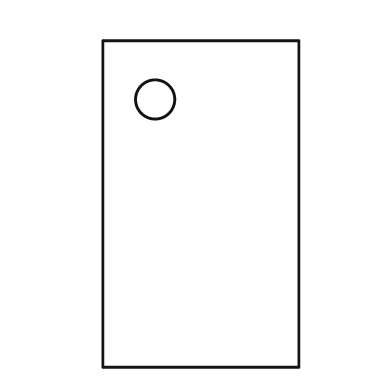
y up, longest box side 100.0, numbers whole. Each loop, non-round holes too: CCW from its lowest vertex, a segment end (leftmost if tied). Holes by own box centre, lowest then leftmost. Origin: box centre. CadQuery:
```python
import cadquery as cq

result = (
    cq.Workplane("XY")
    .moveTo(-30.0, -50.0)
    .lineTo(30.0, -50.0)
    .lineTo(30.0, 50.0)
    .lineTo(-30.0, 50.0)
    .close()
    .moveTo(-14.0, 32.0)
    .circle(6.0)
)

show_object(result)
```